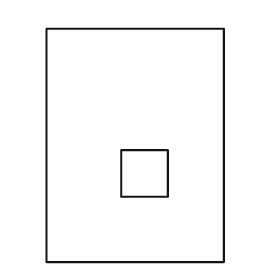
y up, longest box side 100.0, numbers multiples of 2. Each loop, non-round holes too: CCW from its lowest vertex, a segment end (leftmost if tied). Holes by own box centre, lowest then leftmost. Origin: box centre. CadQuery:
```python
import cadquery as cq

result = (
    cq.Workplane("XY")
    .moveTo(-38.0, -50.0)
    .lineTo(38.0, -50.0)
    .lineTo(38.0, 50.0)
    .lineTo(-38.0, 50.0)
    .close()
    .moveTo(-6.0, -22.0)
    .lineTo(14.0, -22.0)
    .lineTo(14.0, -2.0)
    .lineTo(-6.0, -2.0)
    .close()
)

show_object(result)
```